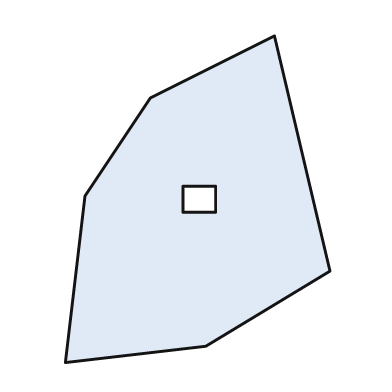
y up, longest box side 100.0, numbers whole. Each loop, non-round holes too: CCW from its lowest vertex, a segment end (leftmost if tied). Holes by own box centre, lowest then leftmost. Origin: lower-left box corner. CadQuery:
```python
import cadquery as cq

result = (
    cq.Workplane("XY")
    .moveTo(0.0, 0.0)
    .lineTo(43.0, 5.0)
    .lineTo(81.0, 28.0)
    .lineTo(64.0, 100.0)
    .lineTo(26.0, 81.0)
    .lineTo(6.0, 51.0)
    .close()
    .moveTo(36.0, 46.0)
    .lineTo(46.0, 46.0)
    .lineTo(46.0, 54.0)
    .lineTo(36.0, 54.0)
    .close()
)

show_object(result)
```